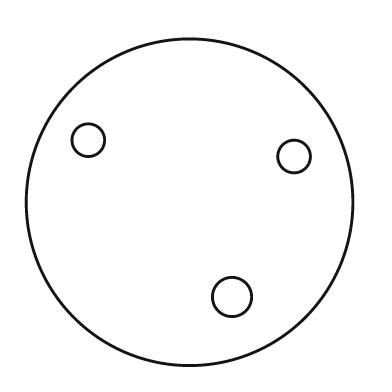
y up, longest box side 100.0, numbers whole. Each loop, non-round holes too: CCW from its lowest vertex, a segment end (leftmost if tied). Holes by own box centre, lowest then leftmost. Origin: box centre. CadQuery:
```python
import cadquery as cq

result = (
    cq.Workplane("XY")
    .moveTo(0.0, 0.0)
    .circle(50.0)
    .moveTo(13.0, -29.0)
    .circle(6.0)
    .moveTo(32.0, 14.0)
    .circle(5.0)
    .moveTo(-31.0, 19.0)
    .circle(5.0)
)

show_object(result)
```